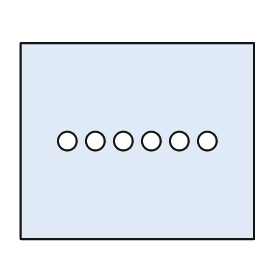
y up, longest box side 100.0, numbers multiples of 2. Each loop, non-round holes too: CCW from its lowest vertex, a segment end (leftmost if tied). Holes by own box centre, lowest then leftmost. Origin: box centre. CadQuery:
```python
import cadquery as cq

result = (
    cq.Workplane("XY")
    .moveTo(-50.0, -42.0)
    .lineTo(50.0, -42.0)
    .lineTo(50.0, 42.0)
    .lineTo(-50.0, 42.0)
    .close()
    .moveTo(-30.0, 0.0)
    .circle(4.0)
    .moveTo(-18.0, 0.0)
    .circle(4.0)
    .moveTo(-6.0, 0.0)
    .circle(4.0)
    .moveTo(6.0, 0.0)
    .circle(4.0)
    .moveTo(18.0, 0.0)
    .circle(4.0)
    .moveTo(30.0, 0.0)
    .circle(4.0)
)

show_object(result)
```